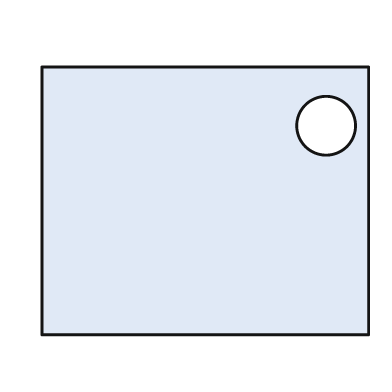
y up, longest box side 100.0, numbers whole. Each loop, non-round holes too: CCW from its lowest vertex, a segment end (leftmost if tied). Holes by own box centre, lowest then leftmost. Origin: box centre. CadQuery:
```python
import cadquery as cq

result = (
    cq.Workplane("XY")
    .moveTo(-50.0, -41.0)
    .lineTo(50.0, -41.0)
    .lineTo(50.0, 41.0)
    .lineTo(-50.0, 41.0)
    .close()
    .moveTo(37.0, 23.0)
    .circle(9.0)
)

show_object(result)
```